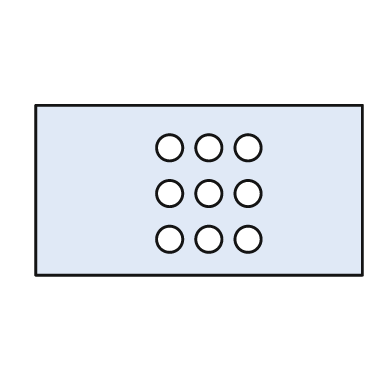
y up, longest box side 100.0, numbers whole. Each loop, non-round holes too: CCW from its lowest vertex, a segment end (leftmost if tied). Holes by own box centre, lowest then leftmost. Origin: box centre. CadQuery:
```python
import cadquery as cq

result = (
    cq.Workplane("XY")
    .moveTo(-50.0, -26.0)
    .lineTo(50.0, -26.0)
    .lineTo(50.0, 26.0)
    .lineTo(-50.0, 26.0)
    .close()
    .moveTo(-9.0, -15.0)
    .circle(4.0)
    .moveTo(3.0, -15.0)
    .circle(4.0)
    .moveTo(15.0, -15.0)
    .circle(4.0)
    .moveTo(-9.0, -1.0)
    .circle(4.0)
    .moveTo(3.0, -1.0)
    .circle(4.0)
    .moveTo(15.0, -1.0)
    .circle(4.0)
    .moveTo(-9.0, 13.0)
    .circle(4.0)
    .moveTo(3.0, 13.0)
    .circle(4.0)
    .moveTo(15.0, 13.0)
    .circle(4.0)
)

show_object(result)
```